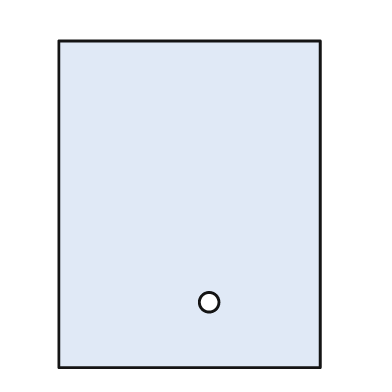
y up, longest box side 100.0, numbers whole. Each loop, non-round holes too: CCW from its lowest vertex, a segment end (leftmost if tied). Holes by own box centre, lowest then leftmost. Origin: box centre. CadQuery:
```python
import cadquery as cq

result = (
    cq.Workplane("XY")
    .moveTo(-40.0, -50.0)
    .lineTo(40.0, -50.0)
    .lineTo(40.0, 50.0)
    .lineTo(-40.0, 50.0)
    .close()
    .moveTo(6.0, -30.0)
    .circle(3.0)
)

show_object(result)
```